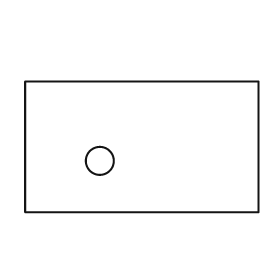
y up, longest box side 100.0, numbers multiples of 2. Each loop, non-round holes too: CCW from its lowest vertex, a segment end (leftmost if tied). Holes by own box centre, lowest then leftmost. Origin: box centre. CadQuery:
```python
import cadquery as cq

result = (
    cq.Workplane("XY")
    .moveTo(-50.0, -28.0)
    .lineTo(50.0, -28.0)
    .lineTo(50.0, 28.0)
    .lineTo(-50.0, 28.0)
    .close()
    .moveTo(-18.0, -6.0)
    .circle(6.0)
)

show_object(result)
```